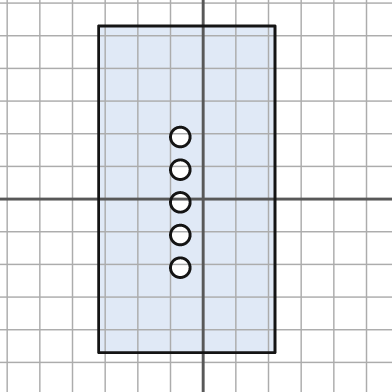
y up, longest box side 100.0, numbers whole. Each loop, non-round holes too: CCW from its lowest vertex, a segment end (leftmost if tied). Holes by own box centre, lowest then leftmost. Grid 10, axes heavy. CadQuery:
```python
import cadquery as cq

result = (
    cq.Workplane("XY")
    .moveTo(-32.0, -47.0)
    .lineTo(22.0, -47.0)
    .lineTo(22.0, 53.0)
    .lineTo(-32.0, 53.0)
    .close()
    .moveTo(-7.0, -21.0)
    .circle(3.0)
    .moveTo(-7.0, -11.0)
    .circle(3.0)
    .moveTo(-7.0, -1.0)
    .circle(3.0)
    .moveTo(-7.0, 9.0)
    .circle(3.0)
    .moveTo(-7.0, 19.0)
    .circle(3.0)
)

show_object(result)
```